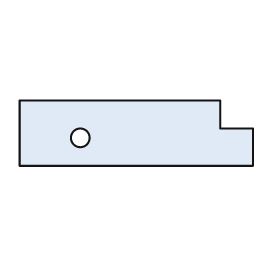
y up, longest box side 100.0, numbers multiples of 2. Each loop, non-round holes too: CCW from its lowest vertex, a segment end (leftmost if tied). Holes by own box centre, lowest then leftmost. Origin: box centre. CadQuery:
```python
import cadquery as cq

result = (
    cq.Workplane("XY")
    .moveTo(-50.0, -14.0)
    .lineTo(50.0, -14.0)
    .lineTo(50.0, 2.0)
    .lineTo(36.0, 2.0)
    .lineTo(36.0, 14.0)
    .lineTo(-50.0, 14.0)
    .close()
    .moveTo(-24.0, -2.0)
    .circle(4.0)
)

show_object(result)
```